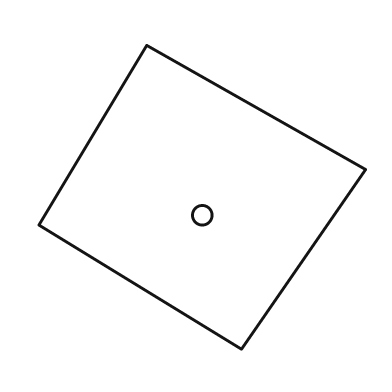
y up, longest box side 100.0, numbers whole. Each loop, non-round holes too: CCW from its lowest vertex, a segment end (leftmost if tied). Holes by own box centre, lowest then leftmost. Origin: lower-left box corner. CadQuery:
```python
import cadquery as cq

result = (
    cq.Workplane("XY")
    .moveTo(62.0, 0.0)
    .lineTo(100.0, 55.0)
    .lineTo(33.0, 93.0)
    .lineTo(0.0, 38.0)
    .close()
    .moveTo(50.0, 41.0)
    .circle(3.0)
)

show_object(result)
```